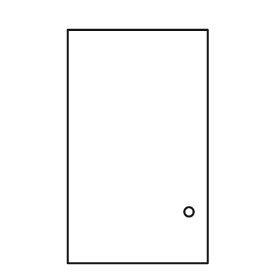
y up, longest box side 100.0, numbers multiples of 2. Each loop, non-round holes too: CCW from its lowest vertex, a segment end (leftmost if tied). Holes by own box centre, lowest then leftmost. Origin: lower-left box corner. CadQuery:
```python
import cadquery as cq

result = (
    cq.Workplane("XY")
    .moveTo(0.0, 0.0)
    .lineTo(60.0, 0.0)
    .lineTo(60.0, 100.0)
    .lineTo(0.0, 100.0)
    .close()
    .moveTo(52.0, 22.0)
    .circle(2.0)
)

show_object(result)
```